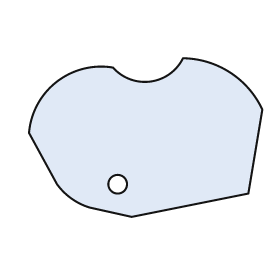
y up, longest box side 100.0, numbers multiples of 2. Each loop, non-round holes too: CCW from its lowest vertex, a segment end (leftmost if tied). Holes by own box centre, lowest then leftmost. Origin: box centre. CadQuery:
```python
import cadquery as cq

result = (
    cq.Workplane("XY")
    .moveTo(-6.0, -34.0)
    .lineTo(44.0, -24.0)
    .lineTo(50.0, 12.0)
    .threePointArc((36.0, 28.0), (16.0, 34.0))
    .threePointArc((2.0, 24.0), (-14.0, 30.0))
    .threePointArc((-38.0, 24.0), (-50.0, 2.0))
    .lineTo(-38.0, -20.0)
    .threePointArc((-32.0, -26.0), (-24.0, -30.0))
    .close()
    .moveTo(-12.0, -20.0)
    .circle(4.0)
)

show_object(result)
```